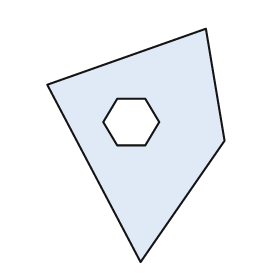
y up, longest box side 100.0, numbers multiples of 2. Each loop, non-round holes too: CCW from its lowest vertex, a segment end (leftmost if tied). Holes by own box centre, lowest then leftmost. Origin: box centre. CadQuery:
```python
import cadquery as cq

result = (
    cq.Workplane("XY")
    .moveTo(2.0, -50.0)
    .lineTo(38.0, 2.0)
    .lineTo(30.0, 50.0)
    .lineTo(-38.0, 26.0)
    .close()
    .moveTo(-8.0, 0.0)
    .lineTo(4.0, 0.0)
    .lineTo(10.0, 10.0)
    .lineTo(4.0, 20.0)
    .lineTo(-8.0, 20.0)
    .lineTo(-14.0, 10.0)
    .close()
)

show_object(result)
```